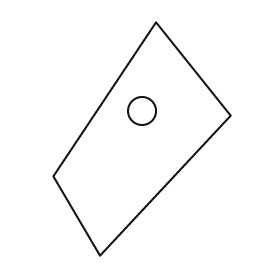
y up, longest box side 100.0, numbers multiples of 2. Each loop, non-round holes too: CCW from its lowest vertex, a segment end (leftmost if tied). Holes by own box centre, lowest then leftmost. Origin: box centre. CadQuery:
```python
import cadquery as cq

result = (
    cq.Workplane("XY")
    .moveTo(-18.0, -50.0)
    .lineTo(38.0, 10.0)
    .lineTo(6.0, 50.0)
    .lineTo(-38.0, -16.0)
    .close()
    .moveTo(0.0, 12.0)
    .circle(6.0)
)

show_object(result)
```